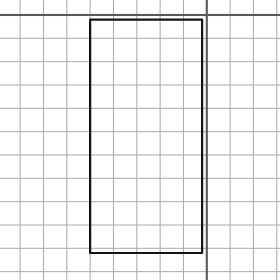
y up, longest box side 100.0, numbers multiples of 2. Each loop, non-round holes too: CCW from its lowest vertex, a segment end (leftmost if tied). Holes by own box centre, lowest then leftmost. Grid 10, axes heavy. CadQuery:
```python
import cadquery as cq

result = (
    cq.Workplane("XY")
    .moveTo(-50.0, -102.0)
    .lineTo(-2.0, -102.0)
    .lineTo(-2.0, -2.0)
    .lineTo(-50.0, -2.0)
    .close()
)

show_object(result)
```